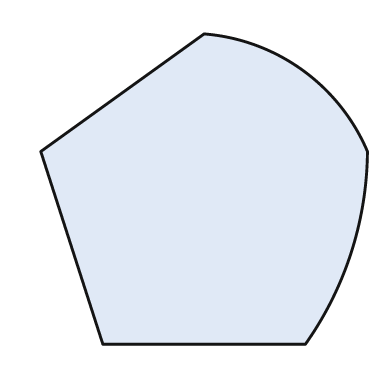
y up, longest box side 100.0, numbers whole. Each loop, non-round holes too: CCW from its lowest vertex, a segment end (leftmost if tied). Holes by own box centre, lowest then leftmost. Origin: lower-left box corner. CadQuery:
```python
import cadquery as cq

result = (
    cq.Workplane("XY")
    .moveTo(19.0, 0.0)
    .lineTo(81.0, 0.0)
    .threePointArc((95.0, 28.0), (100.0, 59.0))
    .threePointArc((80.0, 84.0), (50.0, 95.0))
    .lineTo(0.0, 59.0)
    .close()
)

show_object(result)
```